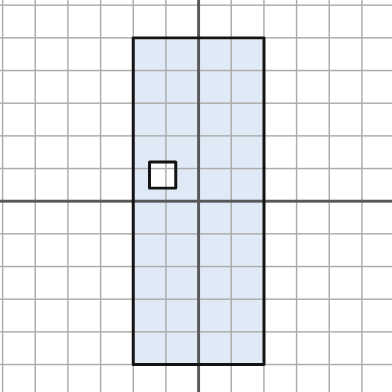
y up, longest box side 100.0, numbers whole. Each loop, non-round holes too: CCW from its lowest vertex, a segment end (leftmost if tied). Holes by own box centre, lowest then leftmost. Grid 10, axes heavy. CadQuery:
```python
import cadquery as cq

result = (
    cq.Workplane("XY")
    .moveTo(-20.0, -50.0)
    .lineTo(20.0, -50.0)
    .lineTo(20.0, 50.0)
    .lineTo(-20.0, 50.0)
    .close()
    .moveTo(-15.0, 4.0)
    .lineTo(-7.0, 4.0)
    .lineTo(-7.0, 12.0)
    .lineTo(-15.0, 12.0)
    .close()
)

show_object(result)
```